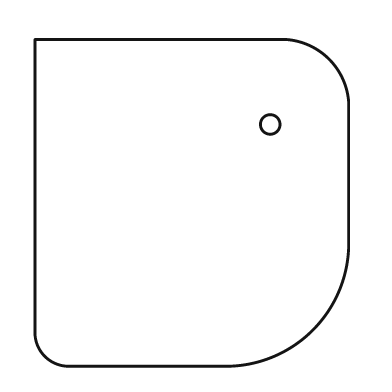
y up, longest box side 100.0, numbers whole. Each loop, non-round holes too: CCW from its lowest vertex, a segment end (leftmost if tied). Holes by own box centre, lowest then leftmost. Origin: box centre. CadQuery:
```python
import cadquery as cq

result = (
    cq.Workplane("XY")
    .moveTo(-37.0, -50.0)
    .lineTo(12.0, -50.0)
    .threePointArc((37.0, -39.0), (48.0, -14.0))
    .lineTo(48.0, 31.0)
    .threePointArc((42.0, 44.0), (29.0, 50.0))
    .lineTo(-48.0, 50.0)
    .lineTo(-48.0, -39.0)
    .threePointArc((-45.0, -47.0), (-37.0, -50.0))
    .close()
    .moveTo(24.0, 24.0)
    .circle(3.0)
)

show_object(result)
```